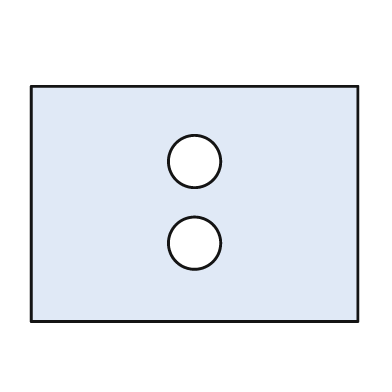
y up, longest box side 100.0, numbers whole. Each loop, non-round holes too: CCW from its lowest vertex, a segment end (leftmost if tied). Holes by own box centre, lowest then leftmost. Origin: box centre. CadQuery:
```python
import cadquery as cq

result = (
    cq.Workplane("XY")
    .moveTo(-50.0, -36.0)
    .lineTo(50.0, -36.0)
    .lineTo(50.0, 36.0)
    .lineTo(-50.0, 36.0)
    .close()
    .moveTo(0.0, -12.0)
    .circle(8.0)
    .moveTo(0.0, 13.0)
    .circle(8.0)
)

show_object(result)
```